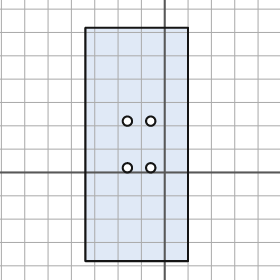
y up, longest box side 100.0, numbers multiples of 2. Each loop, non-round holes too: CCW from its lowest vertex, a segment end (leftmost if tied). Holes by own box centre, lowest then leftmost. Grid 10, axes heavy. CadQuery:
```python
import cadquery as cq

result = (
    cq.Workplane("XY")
    .moveTo(-34.0, -38.0)
    .lineTo(10.0, -38.0)
    .lineTo(10.0, 62.0)
    .lineTo(-34.0, 62.0)
    .close()
    .moveTo(-16.0, 2.0)
    .circle(2.0)
    .moveTo(-6.0, 2.0)
    .circle(2.0)
    .moveTo(-16.0, 22.0)
    .circle(2.0)
    .moveTo(-6.0, 22.0)
    .circle(2.0)
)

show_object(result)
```